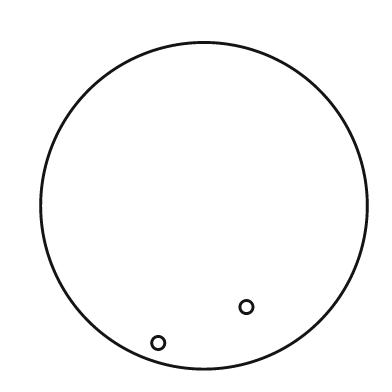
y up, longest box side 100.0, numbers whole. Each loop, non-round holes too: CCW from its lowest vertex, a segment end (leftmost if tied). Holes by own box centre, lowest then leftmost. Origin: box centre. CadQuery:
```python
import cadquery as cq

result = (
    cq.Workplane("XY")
    .moveTo(0.0, 0.0)
    .circle(50.0)
    .moveTo(-14.0, -42.0)
    .circle(2.0)
    .moveTo(13.0, -31.0)
    .circle(2.0)
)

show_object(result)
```